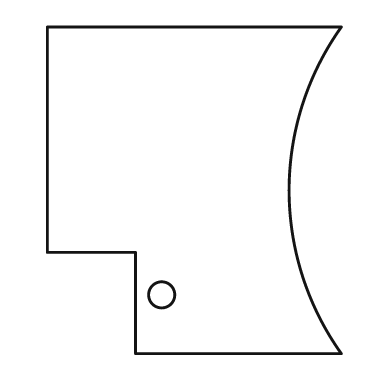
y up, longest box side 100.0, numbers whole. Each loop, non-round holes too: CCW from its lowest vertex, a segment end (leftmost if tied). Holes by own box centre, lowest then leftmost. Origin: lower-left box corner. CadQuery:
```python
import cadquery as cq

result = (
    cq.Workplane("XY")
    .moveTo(27.0, 0.0)
    .lineTo(90.0, 0.0)
    .threePointArc((74.0, 50.0), (90.0, 100.0))
    .lineTo(0.0, 100.0)
    .lineTo(0.0, 31.0)
    .lineTo(27.0, 31.0)
    .close()
    .moveTo(35.0, 18.0)
    .circle(4.0)
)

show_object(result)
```